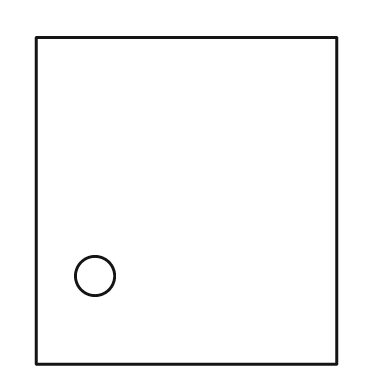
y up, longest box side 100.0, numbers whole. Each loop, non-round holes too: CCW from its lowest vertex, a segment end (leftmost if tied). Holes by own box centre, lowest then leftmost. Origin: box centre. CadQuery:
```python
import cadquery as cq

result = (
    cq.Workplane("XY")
    .moveTo(-46.0, -50.0)
    .lineTo(46.0, -50.0)
    .lineTo(46.0, 50.0)
    .lineTo(-46.0, 50.0)
    .close()
    .moveTo(-28.0, -23.0)
    .circle(6.0)
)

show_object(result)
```